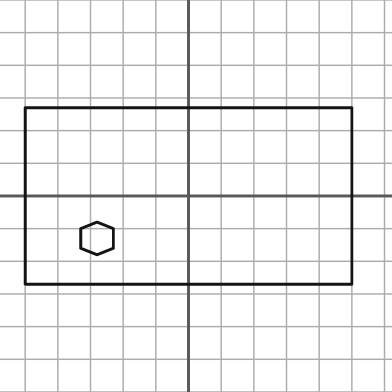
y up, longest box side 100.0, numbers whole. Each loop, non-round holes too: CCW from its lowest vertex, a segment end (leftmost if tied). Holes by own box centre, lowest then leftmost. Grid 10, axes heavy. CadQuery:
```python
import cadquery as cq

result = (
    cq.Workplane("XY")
    .moveTo(-50.0, -27.0)
    .lineTo(50.0, -27.0)
    .lineTo(50.0, 27.0)
    .lineTo(-50.0, 27.0)
    .close()
    .moveTo(-28.0, -18.0)
    .lineTo(-23.0, -16.0)
    .lineTo(-23.0, -10.0)
    .lineTo(-28.0, -8.0)
    .lineTo(-33.0, -10.0)
    .lineTo(-33.0, -16.0)
    .close()
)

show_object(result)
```